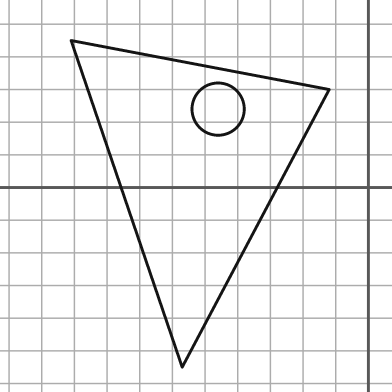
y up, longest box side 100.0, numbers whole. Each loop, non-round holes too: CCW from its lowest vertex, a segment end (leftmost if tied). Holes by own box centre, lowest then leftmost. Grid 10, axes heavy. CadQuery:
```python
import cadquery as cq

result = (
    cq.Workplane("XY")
    .moveTo(-57.0, -55.0)
    .lineTo(-12.0, 30.0)
    .lineTo(-91.0, 45.0)
    .close()
    .moveTo(-46.0, 24.0)
    .circle(8.0)
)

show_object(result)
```